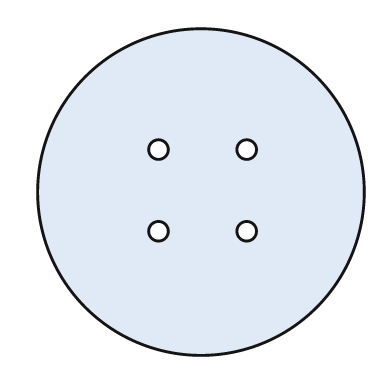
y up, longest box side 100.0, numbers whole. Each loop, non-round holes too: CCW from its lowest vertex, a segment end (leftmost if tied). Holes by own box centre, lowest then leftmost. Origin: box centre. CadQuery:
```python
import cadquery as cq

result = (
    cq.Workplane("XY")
    .moveTo(0.0, 0.0)
    .circle(50.0)
    .moveTo(-13.0, -12.0)
    .circle(3.0)
    .moveTo(14.0, -12.0)
    .circle(3.0)
    .moveTo(-13.0, 13.0)
    .circle(3.0)
    .moveTo(14.0, 13.0)
    .circle(3.0)
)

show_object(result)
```